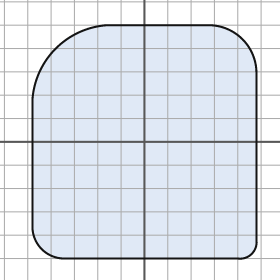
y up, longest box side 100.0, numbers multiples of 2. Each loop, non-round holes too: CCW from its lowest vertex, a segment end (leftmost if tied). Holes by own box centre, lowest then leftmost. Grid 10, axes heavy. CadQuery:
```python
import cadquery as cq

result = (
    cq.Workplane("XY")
    .moveTo(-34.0, -50.0)
    .lineTo(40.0, -50.0)
    .threePointArc((46.0, -48.0), (48.0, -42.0))
    .lineTo(48.0, 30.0)
    .threePointArc((42.0, 44.0), (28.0, 50.0))
    .lineTo(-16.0, 50.0)
    .threePointArc((-38.0, 40.0), (-48.0, 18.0))
    .lineTo(-48.0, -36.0)
    .threePointArc((-44.0, -46.0), (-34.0, -50.0))
    .close()
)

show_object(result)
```